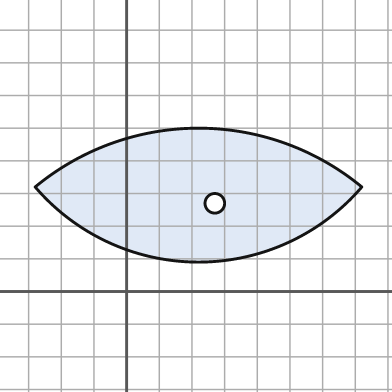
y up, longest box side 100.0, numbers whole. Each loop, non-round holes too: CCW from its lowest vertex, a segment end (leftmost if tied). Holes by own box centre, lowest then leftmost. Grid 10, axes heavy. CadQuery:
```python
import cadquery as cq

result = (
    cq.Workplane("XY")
    .moveTo(-28.0, 32.0)
    .threePointArc((22.0, 9.0), (72.0, 32.0))
    .threePointArc((22.0, 50.0), (-28.0, 32.0))
    .close()
    .moveTo(27.0, 27.0)
    .circle(3.0)
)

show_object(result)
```